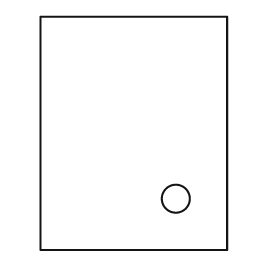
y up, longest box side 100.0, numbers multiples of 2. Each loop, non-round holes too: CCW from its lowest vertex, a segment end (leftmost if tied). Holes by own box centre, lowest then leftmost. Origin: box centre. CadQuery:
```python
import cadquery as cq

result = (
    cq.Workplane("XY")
    .moveTo(-40.0, -50.0)
    .lineTo(40.0, -50.0)
    .lineTo(40.0, 50.0)
    .lineTo(-40.0, 50.0)
    .close()
    .moveTo(18.0, -28.0)
    .circle(6.0)
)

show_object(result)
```